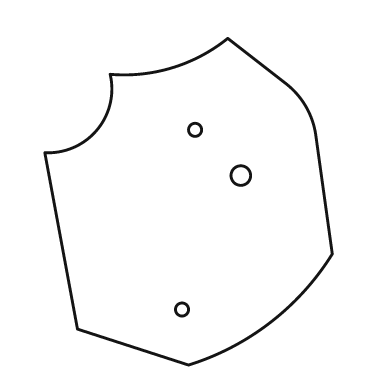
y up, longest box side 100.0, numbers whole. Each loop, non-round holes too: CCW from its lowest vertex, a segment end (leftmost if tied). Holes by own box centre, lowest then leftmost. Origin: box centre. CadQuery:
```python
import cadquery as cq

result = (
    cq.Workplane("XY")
    .moveTo(0.0, -50.0)
    .threePointArc((25.0, -37.0), (44.0, -16.0))
    .lineTo(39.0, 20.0)
    .threePointArc((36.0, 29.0), (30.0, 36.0))
    .lineTo(12.0, 50.0)
    .threePointArc((-5.0, 41.0), (-24.0, 39.0))
    .threePointArc((-28.0, 22.0), (-44.0, 15.0))
    .lineTo(-34.0, -39.0)
    .close()
    .moveTo(-2.0, -33.0)
    .circle(2.0)
    .moveTo(16.0, 8.0)
    .circle(3.0)
    .moveTo(2.0, 22.0)
    .circle(2.0)
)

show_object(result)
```